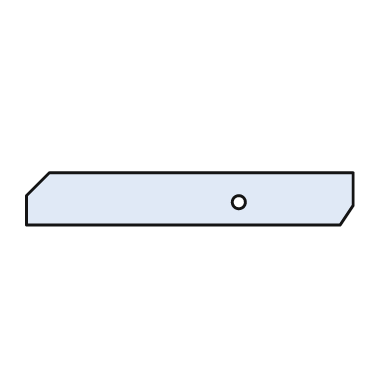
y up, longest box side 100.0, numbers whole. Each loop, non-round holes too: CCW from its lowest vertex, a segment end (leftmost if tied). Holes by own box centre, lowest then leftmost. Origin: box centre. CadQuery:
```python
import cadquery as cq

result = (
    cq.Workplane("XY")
    .moveTo(-50.0, -8.0)
    .lineTo(46.0, -8.0)
    .lineTo(50.0, -2.0)
    .lineTo(50.0, 8.0)
    .lineTo(-43.0, 8.0)
    .lineTo(-50.0, 1.0)
    .close()
    .moveTo(15.0, -1.0)
    .circle(2.0)
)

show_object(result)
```